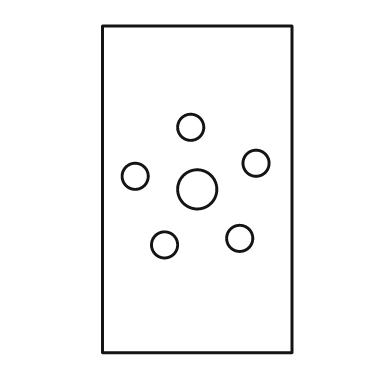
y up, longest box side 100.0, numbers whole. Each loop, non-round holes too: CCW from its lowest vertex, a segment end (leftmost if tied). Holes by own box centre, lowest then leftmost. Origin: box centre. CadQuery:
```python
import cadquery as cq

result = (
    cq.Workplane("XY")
    .moveTo(-29.0, -50.0)
    .lineTo(29.0, -50.0)
    .lineTo(29.0, 50.0)
    .lineTo(-29.0, 50.0)
    .close()
    .moveTo(-10.0, -17.0)
    .circle(4.0)
    .moveTo(13.0, -15.0)
    .circle(4.0)
    .moveTo(0.0, 0.0)
    .circle(6.0)
    .moveTo(-19.0, 4.0)
    .circle(4.0)
    .moveTo(18.0, 8.0)
    .circle(4.0)
    .moveTo(-2.0, 19.0)
    .circle(4.0)
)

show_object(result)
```